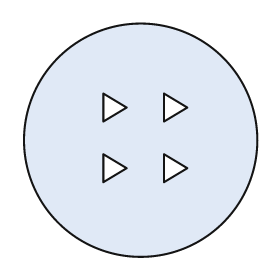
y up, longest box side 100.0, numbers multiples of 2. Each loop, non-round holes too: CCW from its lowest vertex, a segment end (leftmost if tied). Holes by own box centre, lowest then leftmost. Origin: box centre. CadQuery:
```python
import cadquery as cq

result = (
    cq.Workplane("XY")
    .moveTo(0.0, 0.0)
    .circle(50.0)
    .moveTo(-16.0, -18.0)
    .lineTo(-6.0, -12.0)
    .lineTo(-16.0, -6.0)
    .close()
    .moveTo(10.0, -18.0)
    .lineTo(20.0, -12.0)
    .lineTo(10.0, -6.0)
    .close()
    .moveTo(-16.0, 8.0)
    .lineTo(-6.0, 14.0)
    .lineTo(-16.0, 20.0)
    .close()
    .moveTo(10.0, 8.0)
    .lineTo(20.0, 14.0)
    .lineTo(10.0, 20.0)
    .close()
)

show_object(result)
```